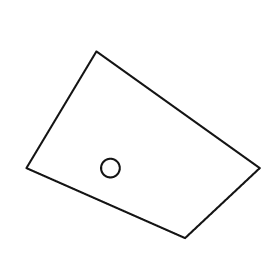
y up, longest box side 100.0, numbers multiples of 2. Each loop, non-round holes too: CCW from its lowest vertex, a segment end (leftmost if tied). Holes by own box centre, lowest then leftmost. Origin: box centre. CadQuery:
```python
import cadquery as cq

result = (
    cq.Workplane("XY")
    .moveTo(18.0, -40.0)
    .lineTo(50.0, -10.0)
    .lineTo(-20.0, 40.0)
    .lineTo(-50.0, -10.0)
    .close()
    .moveTo(-14.0, -10.0)
    .circle(4.0)
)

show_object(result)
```